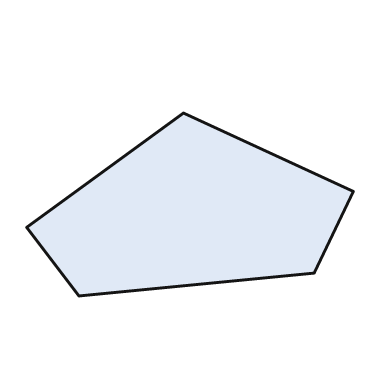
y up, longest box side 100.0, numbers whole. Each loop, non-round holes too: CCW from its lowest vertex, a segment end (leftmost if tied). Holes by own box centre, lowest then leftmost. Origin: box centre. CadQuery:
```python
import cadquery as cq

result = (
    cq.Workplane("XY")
    .moveTo(-34.0, -28.0)
    .lineTo(38.0, -21.0)
    .lineTo(50.0, 4.0)
    .lineTo(-2.0, 28.0)
    .lineTo(-50.0, -7.0)
    .close()
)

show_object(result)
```